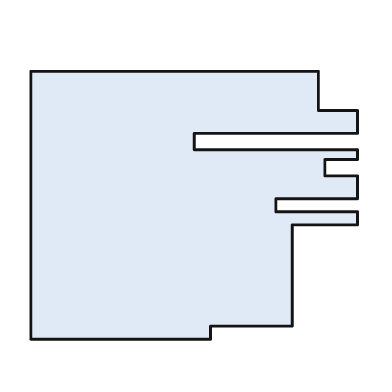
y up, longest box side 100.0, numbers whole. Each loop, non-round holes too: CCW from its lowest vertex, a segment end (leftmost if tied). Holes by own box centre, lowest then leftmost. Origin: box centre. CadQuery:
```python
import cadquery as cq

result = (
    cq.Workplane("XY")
    .moveTo(-50.0, -41.0)
    .lineTo(5.0, -41.0)
    .lineTo(5.0, -37.0)
    .lineTo(30.0, -37.0)
    .lineTo(30.0, -6.0)
    .lineTo(50.0, -6.0)
    .lineTo(50.0, -2.0)
    .lineTo(25.0, -2.0)
    .lineTo(25.0, 2.0)
    .lineTo(50.0, 2.0)
    .lineTo(50.0, 9.0)
    .lineTo(40.0, 9.0)
    .lineTo(40.0, 14.0)
    .lineTo(50.0, 14.0)
    .lineTo(50.0, 17.0)
    .lineTo(0.0, 17.0)
    .lineTo(0.0, 22.0)
    .lineTo(50.0, 22.0)
    .lineTo(50.0, 29.0)
    .lineTo(38.0, 29.0)
    .lineTo(38.0, 41.0)
    .lineTo(-50.0, 41.0)
    .close()
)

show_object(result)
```